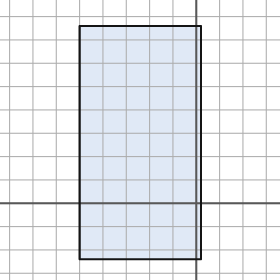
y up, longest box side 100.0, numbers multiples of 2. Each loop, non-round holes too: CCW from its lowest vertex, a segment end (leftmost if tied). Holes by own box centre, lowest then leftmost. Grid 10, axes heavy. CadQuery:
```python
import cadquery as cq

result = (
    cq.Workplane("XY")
    .moveTo(-50.0, -24.0)
    .lineTo(2.0, -24.0)
    .lineTo(2.0, 76.0)
    .lineTo(-50.0, 76.0)
    .close()
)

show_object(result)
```